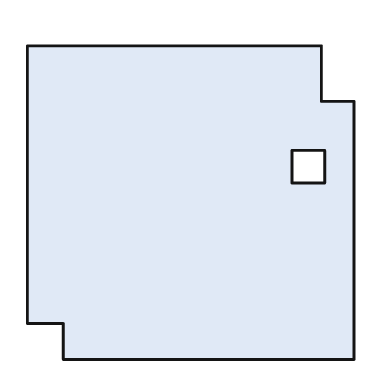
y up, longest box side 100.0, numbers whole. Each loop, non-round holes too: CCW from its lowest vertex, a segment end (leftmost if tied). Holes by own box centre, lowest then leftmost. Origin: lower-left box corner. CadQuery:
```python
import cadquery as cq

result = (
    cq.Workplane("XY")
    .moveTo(11.0, 0.0)
    .lineTo(100.0, 0.0)
    .lineTo(100.0, 79.0)
    .lineTo(90.0, 79.0)
    .lineTo(90.0, 96.0)
    .lineTo(0.0, 96.0)
    .lineTo(0.0, 11.0)
    .lineTo(11.0, 11.0)
    .close()
    .moveTo(81.0, 54.0)
    .lineTo(91.0, 54.0)
    .lineTo(91.0, 64.0)
    .lineTo(81.0, 64.0)
    .close()
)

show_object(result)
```